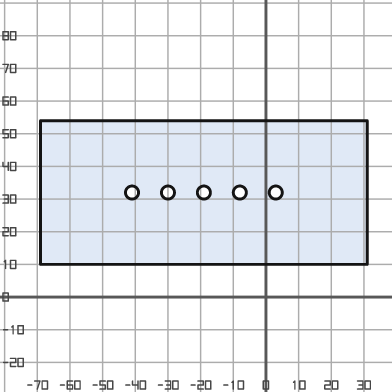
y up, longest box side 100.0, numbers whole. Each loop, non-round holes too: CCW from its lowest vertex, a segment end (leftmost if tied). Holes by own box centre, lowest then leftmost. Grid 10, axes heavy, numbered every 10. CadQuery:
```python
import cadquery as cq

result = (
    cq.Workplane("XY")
    .moveTo(-69.0, 10.0)
    .lineTo(31.0, 10.0)
    .lineTo(31.0, 54.0)
    .lineTo(-69.0, 54.0)
    .close()
    .moveTo(-41.0, 32.0)
    .circle(2.0)
    .moveTo(-30.0, 32.0)
    .circle(2.0)
    .moveTo(-19.0, 32.0)
    .circle(2.0)
    .moveTo(-8.0, 32.0)
    .circle(2.0)
    .moveTo(3.0, 32.0)
    .circle(2.0)
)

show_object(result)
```